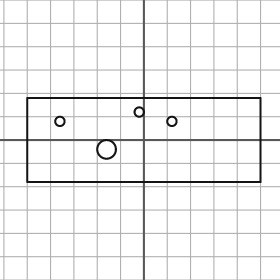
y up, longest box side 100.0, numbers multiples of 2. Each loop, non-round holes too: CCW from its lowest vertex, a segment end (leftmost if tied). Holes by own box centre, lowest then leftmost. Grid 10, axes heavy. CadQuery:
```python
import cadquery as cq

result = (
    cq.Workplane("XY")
    .moveTo(-50.0, -18.0)
    .lineTo(50.0, -18.0)
    .lineTo(50.0, 18.0)
    .lineTo(-50.0, 18.0)
    .close()
    .moveTo(-16.0, -4.0)
    .circle(4.0)
    .moveTo(-36.0, 8.0)
    .circle(2.0)
    .moveTo(12.0, 8.0)
    .circle(2.0)
    .moveTo(-2.0, 12.0)
    .circle(2.0)
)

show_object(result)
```